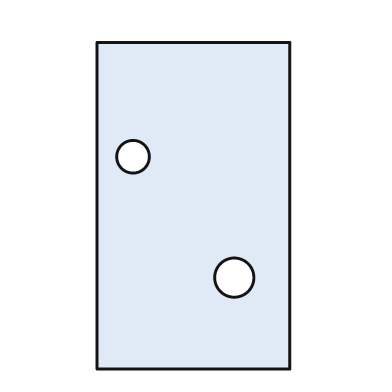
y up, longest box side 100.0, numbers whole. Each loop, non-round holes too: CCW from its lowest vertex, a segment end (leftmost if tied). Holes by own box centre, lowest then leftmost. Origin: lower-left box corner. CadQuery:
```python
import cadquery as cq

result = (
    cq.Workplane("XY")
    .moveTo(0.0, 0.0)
    .lineTo(59.0, 0.0)
    .lineTo(59.0, 100.0)
    .lineTo(0.0, 100.0)
    .close()
    .moveTo(42.0, 28.0)
    .circle(6.0)
    .moveTo(11.0, 65.0)
    .circle(5.0)
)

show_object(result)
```